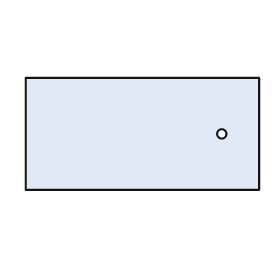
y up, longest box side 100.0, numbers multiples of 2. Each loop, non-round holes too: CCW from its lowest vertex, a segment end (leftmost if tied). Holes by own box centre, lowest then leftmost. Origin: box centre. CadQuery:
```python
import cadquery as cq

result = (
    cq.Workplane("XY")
    .moveTo(-50.0, -24.0)
    .lineTo(50.0, -24.0)
    .lineTo(50.0, 24.0)
    .lineTo(-50.0, 24.0)
    .close()
    .moveTo(34.0, 0.0)
    .circle(2.0)
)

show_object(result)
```